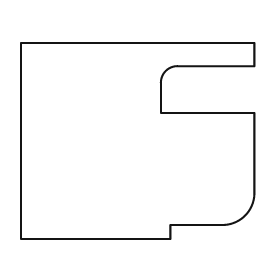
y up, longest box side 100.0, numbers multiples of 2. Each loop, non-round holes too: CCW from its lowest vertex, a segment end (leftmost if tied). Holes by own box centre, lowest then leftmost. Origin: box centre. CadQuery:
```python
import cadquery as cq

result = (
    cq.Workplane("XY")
    .moveTo(-50.0, -42.0)
    .lineTo(14.0, -42.0)
    .lineTo(14.0, -36.0)
    .lineTo(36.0, -36.0)
    .threePointArc((46.0, -32.0), (50.0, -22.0))
    .lineTo(50.0, 12.0)
    .lineTo(10.0, 12.0)
    .lineTo(10.0, 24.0)
    .threePointArc((12.0, 30.0), (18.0, 32.0))
    .lineTo(50.0, 32.0)
    .lineTo(50.0, 42.0)
    .lineTo(-50.0, 42.0)
    .close()
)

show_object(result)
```